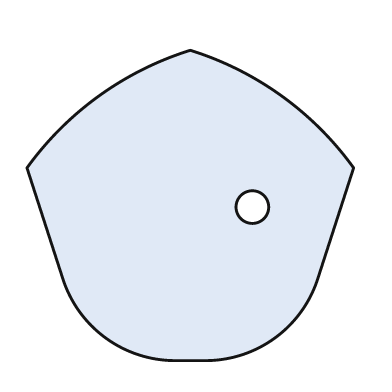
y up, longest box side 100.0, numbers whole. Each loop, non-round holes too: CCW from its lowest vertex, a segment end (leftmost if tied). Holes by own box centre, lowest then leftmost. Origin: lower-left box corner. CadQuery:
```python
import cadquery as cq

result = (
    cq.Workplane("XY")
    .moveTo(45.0, 0.0)
    .lineTo(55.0, 0.0)
    .threePointArc((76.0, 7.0), (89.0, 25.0))
    .lineTo(100.0, 59.0)
    .threePointArc((78.0, 81.0), (50.0, 95.0))
    .threePointArc((22.0, 81.0), (0.0, 59.0))
    .lineTo(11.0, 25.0)
    .threePointArc((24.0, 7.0), (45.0, 0.0))
    .close()
    .moveTo(69.0, 47.0)
    .circle(5.0)
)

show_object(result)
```